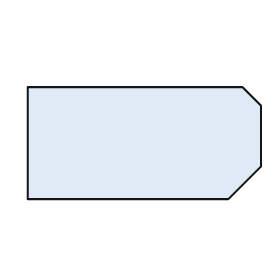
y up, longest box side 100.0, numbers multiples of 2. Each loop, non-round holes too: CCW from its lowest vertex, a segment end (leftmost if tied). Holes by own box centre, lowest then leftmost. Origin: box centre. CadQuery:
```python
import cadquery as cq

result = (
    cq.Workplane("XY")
    .moveTo(-50.0, -24.0)
    .lineTo(36.0, -24.0)
    .lineTo(50.0, -10.0)
    .lineTo(50.0, 16.0)
    .lineTo(42.0, 24.0)
    .lineTo(-50.0, 24.0)
    .close()
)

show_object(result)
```